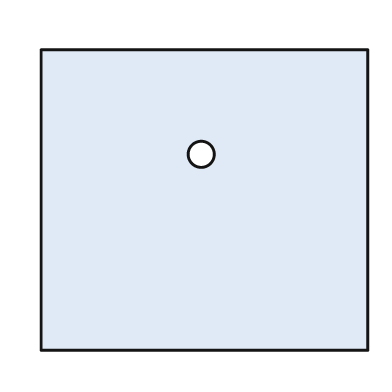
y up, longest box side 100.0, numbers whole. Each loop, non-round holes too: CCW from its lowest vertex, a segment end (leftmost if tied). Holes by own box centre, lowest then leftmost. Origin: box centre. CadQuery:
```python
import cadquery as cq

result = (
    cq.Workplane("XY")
    .moveTo(-50.0, -46.0)
    .lineTo(50.0, -46.0)
    .lineTo(50.0, 46.0)
    .lineTo(-50.0, 46.0)
    .close()
    .moveTo(-1.0, 14.0)
    .circle(4.0)
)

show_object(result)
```